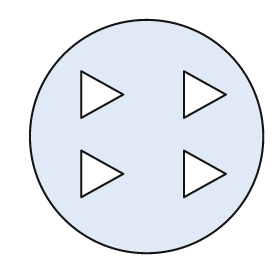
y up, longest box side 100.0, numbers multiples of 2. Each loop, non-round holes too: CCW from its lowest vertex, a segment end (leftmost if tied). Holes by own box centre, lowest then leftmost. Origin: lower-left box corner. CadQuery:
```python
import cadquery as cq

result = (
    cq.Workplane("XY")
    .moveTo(50.0, 50.0)
    .circle(50.0)
    .moveTo(22.0, 24.0)
    .lineTo(40.0, 34.0)
    .lineTo(22.0, 44.0)
    .close()
    .moveTo(66.0, 24.0)
    .lineTo(84.0, 34.0)
    .lineTo(66.0, 44.0)
    .close()
    .moveTo(22.0, 58.0)
    .lineTo(40.0, 68.0)
    .lineTo(22.0, 78.0)
    .close()
    .moveTo(66.0, 58.0)
    .lineTo(84.0, 68.0)
    .lineTo(66.0, 78.0)
    .close()
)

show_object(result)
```